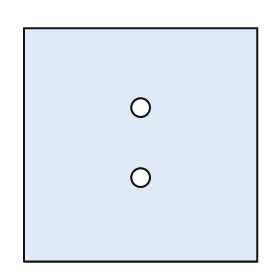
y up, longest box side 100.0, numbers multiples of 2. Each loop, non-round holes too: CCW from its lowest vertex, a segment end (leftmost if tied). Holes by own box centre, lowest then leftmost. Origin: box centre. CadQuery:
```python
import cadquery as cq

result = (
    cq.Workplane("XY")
    .moveTo(-50.0, -50.0)
    .lineTo(50.0, -50.0)
    .lineTo(50.0, 50.0)
    .lineTo(-50.0, 50.0)
    .close()
    .moveTo(0.0, -14.0)
    .circle(4.0)
    .moveTo(0.0, 16.0)
    .circle(4.0)
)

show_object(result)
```